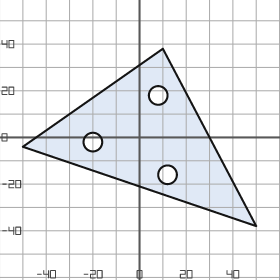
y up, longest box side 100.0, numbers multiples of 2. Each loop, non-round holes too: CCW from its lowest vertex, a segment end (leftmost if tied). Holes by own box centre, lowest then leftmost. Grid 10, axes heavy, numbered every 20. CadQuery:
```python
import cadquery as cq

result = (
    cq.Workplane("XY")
    .moveTo(50.0, -38.0)
    .lineTo(10.0, 38.0)
    .lineTo(-50.0, -4.0)
    .close()
    .moveTo(12.0, -16.0)
    .circle(4.0)
    .moveTo(-20.0, -2.0)
    .circle(4.0)
    .moveTo(8.0, 18.0)
    .circle(4.0)
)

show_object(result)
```